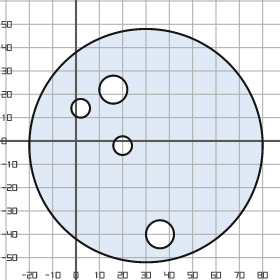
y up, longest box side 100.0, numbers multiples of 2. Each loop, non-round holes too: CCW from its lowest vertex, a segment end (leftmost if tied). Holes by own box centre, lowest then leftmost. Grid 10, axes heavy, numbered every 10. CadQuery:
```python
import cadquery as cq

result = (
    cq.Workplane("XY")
    .moveTo(30.0, -2.0)
    .circle(50.0)
    .moveTo(36.0, -40.0)
    .circle(6.0)
    .moveTo(20.0, -2.0)
    .circle(4.0)
    .moveTo(2.0, 14.0)
    .circle(4.0)
    .moveTo(16.0, 22.0)
    .circle(6.0)
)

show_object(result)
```